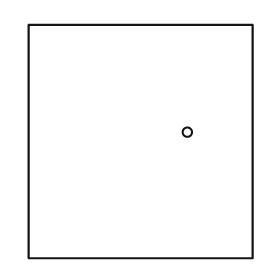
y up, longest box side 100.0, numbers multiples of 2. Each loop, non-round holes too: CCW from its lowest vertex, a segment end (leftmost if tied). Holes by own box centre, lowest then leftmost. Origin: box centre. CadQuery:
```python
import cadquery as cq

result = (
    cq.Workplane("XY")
    .moveTo(-48.0, -50.0)
    .lineTo(48.0, -50.0)
    .lineTo(48.0, 50.0)
    .lineTo(-48.0, 50.0)
    .close()
    .moveTo(20.0, 4.0)
    .circle(2.0)
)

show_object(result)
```